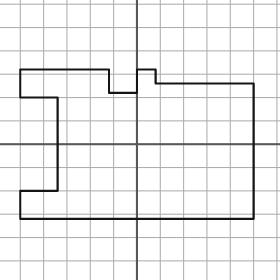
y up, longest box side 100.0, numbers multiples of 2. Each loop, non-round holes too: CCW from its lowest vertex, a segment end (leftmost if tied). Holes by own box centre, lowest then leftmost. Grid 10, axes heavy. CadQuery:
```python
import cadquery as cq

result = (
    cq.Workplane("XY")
    .moveTo(-50.0, -32.0)
    .lineTo(50.0, -32.0)
    .lineTo(50.0, 26.0)
    .lineTo(8.0, 26.0)
    .lineTo(8.0, 32.0)
    .lineTo(0.0, 32.0)
    .lineTo(0.0, 22.0)
    .lineTo(-12.0, 22.0)
    .lineTo(-12.0, 32.0)
    .lineTo(-50.0, 32.0)
    .lineTo(-50.0, 20.0)
    .lineTo(-34.0, 20.0)
    .lineTo(-34.0, -20.0)
    .lineTo(-50.0, -20.0)
    .close()
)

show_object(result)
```